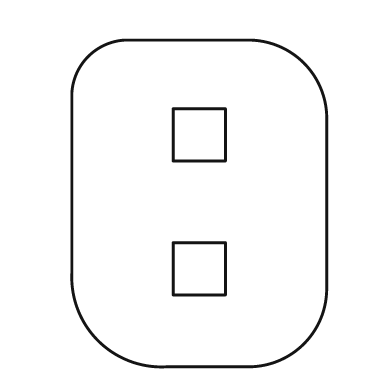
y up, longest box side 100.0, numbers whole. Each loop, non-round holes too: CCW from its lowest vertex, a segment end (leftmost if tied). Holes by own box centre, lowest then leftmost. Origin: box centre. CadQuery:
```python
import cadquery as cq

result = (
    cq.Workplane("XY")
    .moveTo(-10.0, -50.0)
    .lineTo(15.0, -50.0)
    .threePointArc((32.0, -43.0), (39.0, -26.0))
    .lineTo(39.0, 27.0)
    .threePointArc((32.0, 43.0), (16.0, 50.0))
    .lineTo(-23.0, 50.0)
    .threePointArc((-34.0, 45.0), (-39.0, 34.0))
    .lineTo(-39.0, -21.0)
    .threePointArc((-31.0, -42.0), (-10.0, -50.0))
    .close()
    .moveTo(-8.0, -28.0)
    .lineTo(8.0, -28.0)
    .lineTo(8.0, -12.0)
    .lineTo(-8.0, -12.0)
    .close()
    .moveTo(-8.0, 13.0)
    .lineTo(8.0, 13.0)
    .lineTo(8.0, 29.0)
    .lineTo(-8.0, 29.0)
    .close()
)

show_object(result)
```